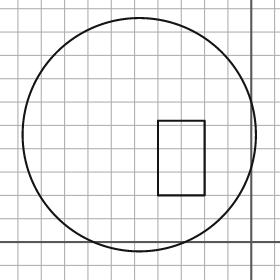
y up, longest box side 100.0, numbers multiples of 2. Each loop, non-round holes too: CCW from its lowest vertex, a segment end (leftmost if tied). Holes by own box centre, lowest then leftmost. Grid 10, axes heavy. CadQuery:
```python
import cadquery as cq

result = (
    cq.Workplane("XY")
    .moveTo(-48.0, 46.0)
    .circle(50.0)
    .moveTo(-40.0, 20.0)
    .lineTo(-20.0, 20.0)
    .lineTo(-20.0, 52.0)
    .lineTo(-40.0, 52.0)
    .close()
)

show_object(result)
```